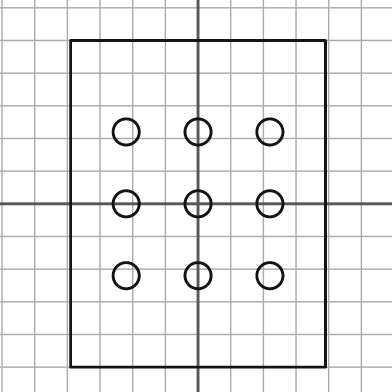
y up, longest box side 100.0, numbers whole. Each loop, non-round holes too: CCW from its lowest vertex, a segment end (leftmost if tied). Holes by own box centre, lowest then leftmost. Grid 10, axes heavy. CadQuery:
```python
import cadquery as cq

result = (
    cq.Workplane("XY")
    .moveTo(-39.0, -50.0)
    .lineTo(39.0, -50.0)
    .lineTo(39.0, 50.0)
    .lineTo(-39.0, 50.0)
    .close()
    .moveTo(-22.0, -22.0)
    .circle(4.0)
    .moveTo(0.0, -22.0)
    .circle(4.0)
    .moveTo(22.0, -22.0)
    .circle(4.0)
    .moveTo(-22.0, 0.0)
    .circle(4.0)
    .moveTo(0.0, 0.0)
    .circle(4.0)
    .moveTo(22.0, 0.0)
    .circle(4.0)
    .moveTo(-22.0, 22.0)
    .circle(4.0)
    .moveTo(0.0, 22.0)
    .circle(4.0)
    .moveTo(22.0, 22.0)
    .circle(4.0)
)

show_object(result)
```